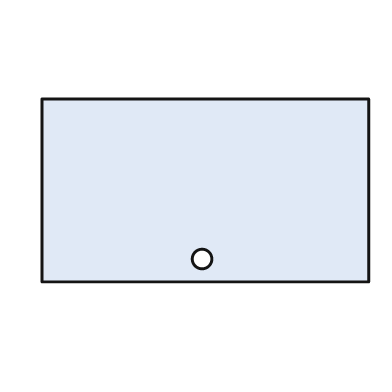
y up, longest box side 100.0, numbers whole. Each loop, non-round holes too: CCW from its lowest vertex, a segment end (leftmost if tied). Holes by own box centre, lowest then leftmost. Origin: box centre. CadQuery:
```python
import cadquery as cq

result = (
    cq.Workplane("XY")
    .moveTo(-50.0, -28.0)
    .lineTo(50.0, -28.0)
    .lineTo(50.0, 28.0)
    .lineTo(-50.0, 28.0)
    .close()
    .moveTo(-1.0, -21.0)
    .circle(3.0)
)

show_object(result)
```